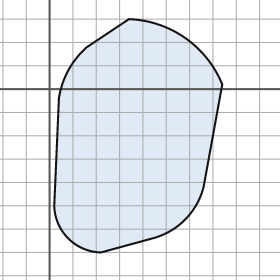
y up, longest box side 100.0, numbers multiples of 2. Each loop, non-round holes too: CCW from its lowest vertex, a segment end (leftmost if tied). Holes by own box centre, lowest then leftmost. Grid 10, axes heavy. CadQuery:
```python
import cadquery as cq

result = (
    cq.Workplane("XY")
    .moveTo(22.0, -70.0)
    .lineTo(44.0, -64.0)
    .threePointArc((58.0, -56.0), (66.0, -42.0))
    .lineTo(74.0, 2.0)
    .threePointArc((58.0, 22.0), (34.0, 30.0))
    .lineTo(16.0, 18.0)
    .threePointArc((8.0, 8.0), (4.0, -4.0))
    .lineTo(2.0, -50.0)
    .threePointArc((8.0, -64.0), (22.0, -70.0))
    .close()
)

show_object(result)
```